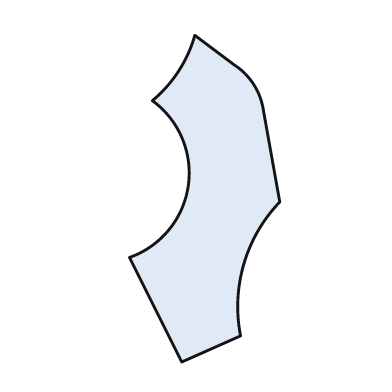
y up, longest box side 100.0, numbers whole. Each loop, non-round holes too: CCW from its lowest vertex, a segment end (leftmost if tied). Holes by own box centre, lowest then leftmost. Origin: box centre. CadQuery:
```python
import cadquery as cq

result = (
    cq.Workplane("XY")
    .moveTo(-7.0, -50.0)
    .lineTo(11.0, -42.0)
    .threePointArc((12.0, -20.0), (23.0, -1.0))
    .lineTo(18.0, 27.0)
    .threePointArc((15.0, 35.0), (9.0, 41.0))
    .lineTo(-3.0, 50.0)
    .threePointArc((-8.0, 39.0), (-16.0, 30.0))
    .threePointArc((-5.0, 4.0), (-23.0, -18.0))
    .close()
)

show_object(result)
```